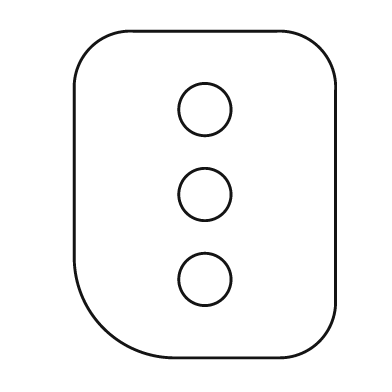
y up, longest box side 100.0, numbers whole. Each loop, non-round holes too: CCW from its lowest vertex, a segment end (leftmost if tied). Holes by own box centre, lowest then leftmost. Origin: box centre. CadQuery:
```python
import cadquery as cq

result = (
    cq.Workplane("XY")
    .moveTo(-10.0, -50.0)
    .lineTo(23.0, -50.0)
    .threePointArc((35.0, -45.0), (40.0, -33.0))
    .lineTo(40.0, 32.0)
    .threePointArc((35.0, 45.0), (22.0, 50.0))
    .lineTo(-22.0, 50.0)
    .threePointArc((-35.0, 45.0), (-40.0, 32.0))
    .lineTo(-40.0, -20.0)
    .threePointArc((-31.0, -41.0), (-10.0, -50.0))
    .close()
    .moveTo(0.0, -26.0)
    .circle(8.0)
    .moveTo(0.0, 0.0)
    .circle(8.0)
    .moveTo(0.0, 26.0)
    .circle(8.0)
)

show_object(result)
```